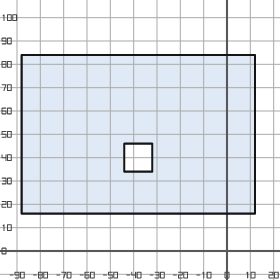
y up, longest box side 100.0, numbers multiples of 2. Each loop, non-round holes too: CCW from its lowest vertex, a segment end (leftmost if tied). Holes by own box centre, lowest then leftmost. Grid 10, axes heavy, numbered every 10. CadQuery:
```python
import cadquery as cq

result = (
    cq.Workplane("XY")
    .moveTo(-88.0, 16.0)
    .lineTo(12.0, 16.0)
    .lineTo(12.0, 84.0)
    .lineTo(-88.0, 84.0)
    .close()
    .moveTo(-44.0, 34.0)
    .lineTo(-32.0, 34.0)
    .lineTo(-32.0, 46.0)
    .lineTo(-44.0, 46.0)
    .close()
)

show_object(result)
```